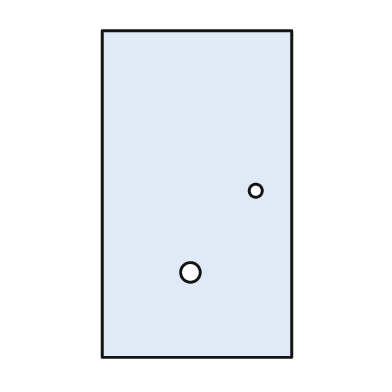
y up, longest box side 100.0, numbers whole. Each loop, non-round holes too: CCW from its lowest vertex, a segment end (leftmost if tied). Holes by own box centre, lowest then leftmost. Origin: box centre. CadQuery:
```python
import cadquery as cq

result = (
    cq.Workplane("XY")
    .moveTo(-29.0, -50.0)
    .lineTo(29.0, -50.0)
    .lineTo(29.0, 50.0)
    .lineTo(-29.0, 50.0)
    .close()
    .moveTo(-2.0, -24.0)
    .circle(3.0)
    .moveTo(18.0, 1.0)
    .circle(2.0)
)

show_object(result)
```